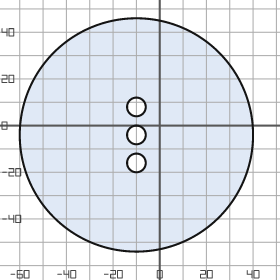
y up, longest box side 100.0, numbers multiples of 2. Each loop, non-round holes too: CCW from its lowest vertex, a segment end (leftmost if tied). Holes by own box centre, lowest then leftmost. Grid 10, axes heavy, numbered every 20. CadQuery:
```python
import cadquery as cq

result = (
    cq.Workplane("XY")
    .moveTo(-10.0, -4.0)
    .circle(50.0)
    .moveTo(-10.0, -16.0)
    .circle(4.0)
    .moveTo(-10.0, -4.0)
    .circle(4.0)
    .moveTo(-10.0, 8.0)
    .circle(4.0)
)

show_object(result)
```